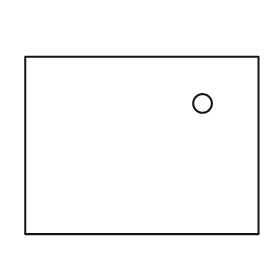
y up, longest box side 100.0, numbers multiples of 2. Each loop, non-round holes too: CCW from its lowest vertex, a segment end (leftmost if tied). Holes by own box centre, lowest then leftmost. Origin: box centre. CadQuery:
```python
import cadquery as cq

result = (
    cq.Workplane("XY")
    .moveTo(-50.0, -38.0)
    .lineTo(50.0, -38.0)
    .lineTo(50.0, 38.0)
    .lineTo(-50.0, 38.0)
    .close()
    .moveTo(26.0, 18.0)
    .circle(4.0)
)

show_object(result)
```